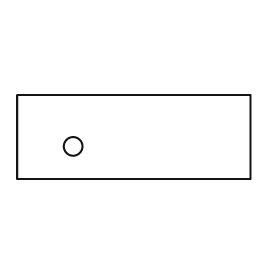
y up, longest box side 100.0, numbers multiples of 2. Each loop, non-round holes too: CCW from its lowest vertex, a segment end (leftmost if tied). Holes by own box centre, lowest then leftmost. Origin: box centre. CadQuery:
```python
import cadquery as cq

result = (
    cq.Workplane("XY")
    .moveTo(-50.0, -18.0)
    .lineTo(50.0, -18.0)
    .lineTo(50.0, 18.0)
    .lineTo(-50.0, 18.0)
    .close()
    .moveTo(-26.0, -4.0)
    .circle(4.0)
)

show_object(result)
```